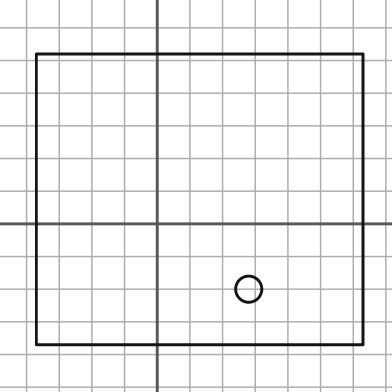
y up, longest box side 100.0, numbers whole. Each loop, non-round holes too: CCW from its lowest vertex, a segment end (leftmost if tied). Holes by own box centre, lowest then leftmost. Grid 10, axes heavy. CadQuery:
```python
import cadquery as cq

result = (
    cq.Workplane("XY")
    .moveTo(-37.0, -37.0)
    .lineTo(63.0, -37.0)
    .lineTo(63.0, 52.0)
    .lineTo(-37.0, 52.0)
    .close()
    .moveTo(28.0, -20.0)
    .circle(4.0)
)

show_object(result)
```